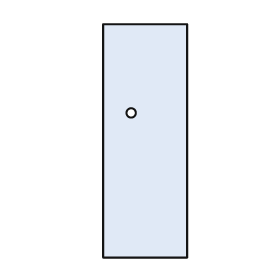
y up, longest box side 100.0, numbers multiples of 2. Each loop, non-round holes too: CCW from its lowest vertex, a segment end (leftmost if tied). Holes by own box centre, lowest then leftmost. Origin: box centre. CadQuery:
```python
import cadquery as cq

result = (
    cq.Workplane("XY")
    .moveTo(-18.0, -50.0)
    .lineTo(18.0, -50.0)
    .lineTo(18.0, 50.0)
    .lineTo(-18.0, 50.0)
    .close()
    .moveTo(-6.0, 12.0)
    .circle(2.0)
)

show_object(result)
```